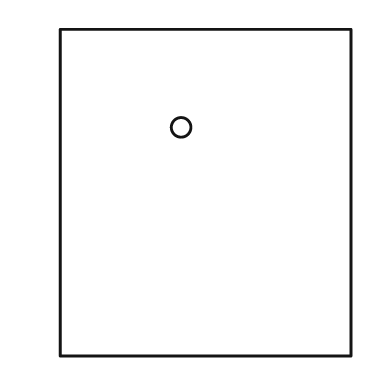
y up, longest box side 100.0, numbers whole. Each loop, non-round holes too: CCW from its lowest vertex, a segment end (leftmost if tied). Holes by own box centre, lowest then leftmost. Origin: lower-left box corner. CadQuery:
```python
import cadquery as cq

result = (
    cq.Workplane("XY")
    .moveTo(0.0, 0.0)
    .lineTo(89.0, 0.0)
    .lineTo(89.0, 100.0)
    .lineTo(0.0, 100.0)
    .close()
    .moveTo(37.0, 70.0)
    .circle(3.0)
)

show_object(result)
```